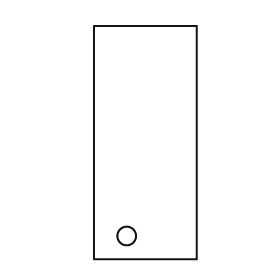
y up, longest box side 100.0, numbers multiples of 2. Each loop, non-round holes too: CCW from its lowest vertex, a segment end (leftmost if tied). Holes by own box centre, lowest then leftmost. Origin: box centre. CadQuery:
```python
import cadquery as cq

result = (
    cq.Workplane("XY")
    .moveTo(-22.0, -50.0)
    .lineTo(22.0, -50.0)
    .lineTo(22.0, 50.0)
    .lineTo(-22.0, 50.0)
    .close()
    .moveTo(-8.0, -40.0)
    .circle(4.0)
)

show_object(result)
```